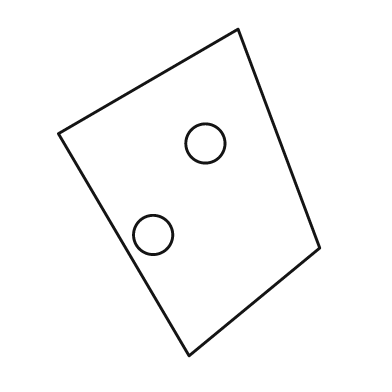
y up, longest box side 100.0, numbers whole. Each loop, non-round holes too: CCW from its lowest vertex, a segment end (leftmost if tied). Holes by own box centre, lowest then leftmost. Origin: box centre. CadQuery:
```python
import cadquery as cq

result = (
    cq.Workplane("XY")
    .moveTo(0.0, -50.0)
    .lineTo(40.0, -17.0)
    .lineTo(15.0, 50.0)
    .lineTo(-40.0, 18.0)
    .close()
    .moveTo(-11.0, -13.0)
    .circle(6.0)
    .moveTo(5.0, 15.0)
    .circle(6.0)
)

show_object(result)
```